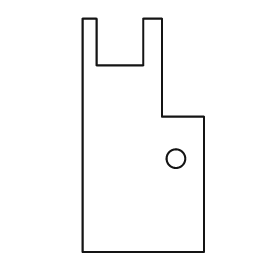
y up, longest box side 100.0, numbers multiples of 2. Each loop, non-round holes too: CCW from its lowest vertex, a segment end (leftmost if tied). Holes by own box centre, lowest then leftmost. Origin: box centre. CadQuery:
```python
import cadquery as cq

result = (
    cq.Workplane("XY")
    .moveTo(-26.0, -50.0)
    .lineTo(26.0, -50.0)
    .lineTo(26.0, 8.0)
    .lineTo(8.0, 8.0)
    .lineTo(8.0, 50.0)
    .lineTo(0.0, 50.0)
    .lineTo(0.0, 30.0)
    .lineTo(-20.0, 30.0)
    .lineTo(-20.0, 50.0)
    .lineTo(-26.0, 50.0)
    .close()
    .moveTo(14.0, -10.0)
    .circle(4.0)
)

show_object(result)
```